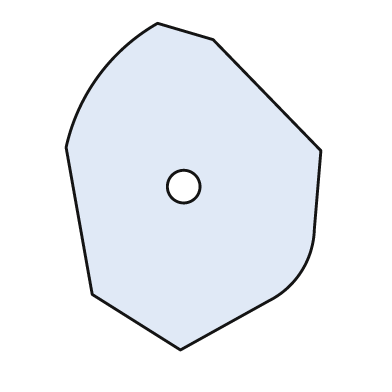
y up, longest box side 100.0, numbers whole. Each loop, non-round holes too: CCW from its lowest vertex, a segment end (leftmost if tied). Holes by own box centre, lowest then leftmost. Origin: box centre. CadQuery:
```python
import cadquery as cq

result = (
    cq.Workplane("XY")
    .moveTo(-4.0, -50.0)
    .lineTo(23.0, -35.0)
    .threePointArc((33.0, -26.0), (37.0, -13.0))
    .lineTo(39.0, 11.0)
    .lineTo(6.0, 45.0)
    .lineTo(-11.0, 50.0)
    .threePointArc((-29.0, 34.0), (-39.0, 12.0))
    .lineTo(-31.0, -33.0)
    .close()
    .moveTo(-3.0, 0.0)
    .circle(5.0)
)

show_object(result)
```